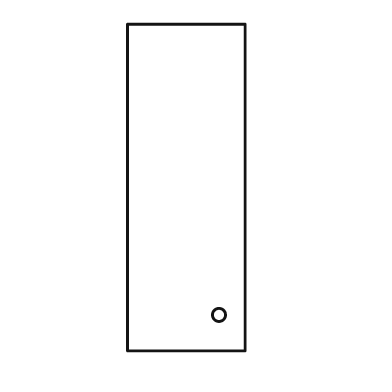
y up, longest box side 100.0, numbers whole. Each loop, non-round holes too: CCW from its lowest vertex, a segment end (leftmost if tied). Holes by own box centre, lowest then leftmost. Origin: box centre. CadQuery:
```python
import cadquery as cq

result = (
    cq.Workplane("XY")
    .moveTo(-18.0, -50.0)
    .lineTo(18.0, -50.0)
    .lineTo(18.0, 50.0)
    .lineTo(-18.0, 50.0)
    .close()
    .moveTo(10.0, -39.0)
    .circle(2.0)
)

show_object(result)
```